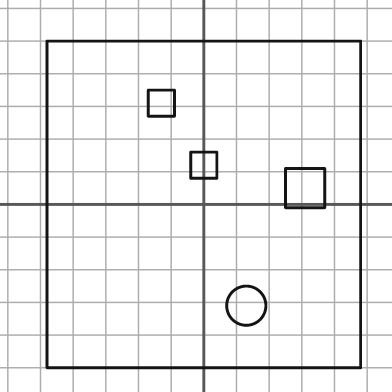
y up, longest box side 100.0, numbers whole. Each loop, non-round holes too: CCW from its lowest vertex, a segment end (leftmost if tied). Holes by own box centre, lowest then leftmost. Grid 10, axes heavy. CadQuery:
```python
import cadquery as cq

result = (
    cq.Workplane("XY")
    .moveTo(-48.0, -50.0)
    .lineTo(48.0, -50.0)
    .lineTo(48.0, 50.0)
    .lineTo(-48.0, 50.0)
    .close()
    .moveTo(13.0, -31.0)
    .circle(6.0)
    .moveTo(25.0, -1.0)
    .lineTo(37.0, -1.0)
    .lineTo(37.0, 11.0)
    .lineTo(25.0, 11.0)
    .close()
    .moveTo(-4.0, 8.0)
    .lineTo(4.0, 8.0)
    .lineTo(4.0, 16.0)
    .lineTo(-4.0, 16.0)
    .close()
    .moveTo(-17.0, 27.0)
    .lineTo(-9.0, 27.0)
    .lineTo(-9.0, 35.0)
    .lineTo(-17.0, 35.0)
    .close()
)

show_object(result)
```